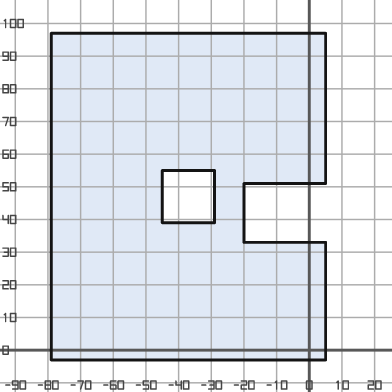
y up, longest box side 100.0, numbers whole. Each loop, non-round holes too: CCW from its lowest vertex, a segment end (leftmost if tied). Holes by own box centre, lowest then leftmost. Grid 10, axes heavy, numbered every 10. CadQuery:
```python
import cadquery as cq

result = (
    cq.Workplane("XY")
    .moveTo(-79.0, -3.0)
    .lineTo(5.0, -3.0)
    .lineTo(5.0, 33.0)
    .lineTo(-20.0, 33.0)
    .lineTo(-20.0, 51.0)
    .lineTo(5.0, 51.0)
    .lineTo(5.0, 97.0)
    .lineTo(-79.0, 97.0)
    .close()
    .moveTo(-45.0, 39.0)
    .lineTo(-29.0, 39.0)
    .lineTo(-29.0, 55.0)
    .lineTo(-45.0, 55.0)
    .close()
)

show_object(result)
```